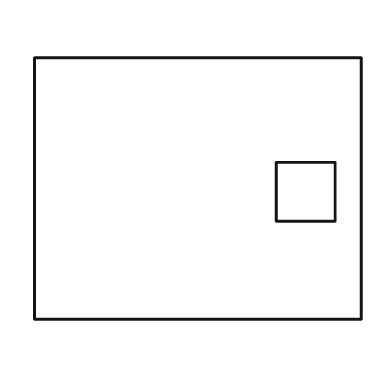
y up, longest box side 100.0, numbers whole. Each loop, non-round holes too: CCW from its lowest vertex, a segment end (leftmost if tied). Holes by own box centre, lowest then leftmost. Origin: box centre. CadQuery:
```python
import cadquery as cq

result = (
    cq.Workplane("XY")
    .moveTo(-50.0, -40.0)
    .lineTo(50.0, -40.0)
    .lineTo(50.0, 40.0)
    .lineTo(-50.0, 40.0)
    .close()
    .moveTo(24.0, -10.0)
    .lineTo(42.0, -10.0)
    .lineTo(42.0, 8.0)
    .lineTo(24.0, 8.0)
    .close()
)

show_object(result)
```